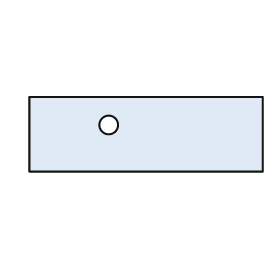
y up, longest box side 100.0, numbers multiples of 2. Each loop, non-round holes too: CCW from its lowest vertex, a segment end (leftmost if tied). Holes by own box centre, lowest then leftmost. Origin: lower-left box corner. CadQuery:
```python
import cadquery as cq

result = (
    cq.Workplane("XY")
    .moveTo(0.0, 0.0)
    .lineTo(100.0, 0.0)
    .lineTo(100.0, 32.0)
    .lineTo(0.0, 32.0)
    .close()
    .moveTo(34.0, 20.0)
    .circle(4.0)
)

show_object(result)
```